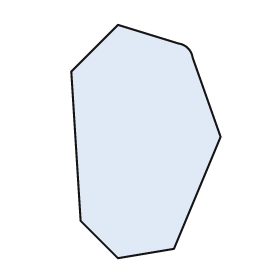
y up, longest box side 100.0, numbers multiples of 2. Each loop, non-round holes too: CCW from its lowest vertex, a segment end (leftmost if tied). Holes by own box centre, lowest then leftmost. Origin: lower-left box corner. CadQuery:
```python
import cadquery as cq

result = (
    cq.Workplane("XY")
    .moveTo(20.0, 0.0)
    .lineTo(44.0, 4.0)
    .lineTo(64.0, 52.0)
    .lineTo(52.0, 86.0)
    .threePointArc((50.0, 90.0), (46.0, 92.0))
    .lineTo(20.0, 100.0)
    .lineTo(0.0, 80.0)
    .lineTo(4.0, 16.0)
    .close()
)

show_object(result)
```